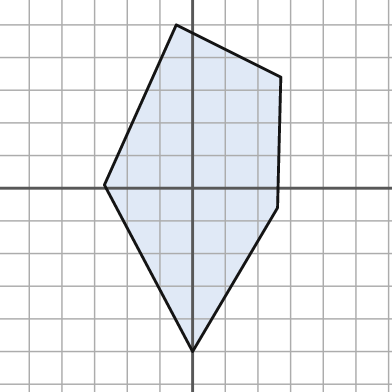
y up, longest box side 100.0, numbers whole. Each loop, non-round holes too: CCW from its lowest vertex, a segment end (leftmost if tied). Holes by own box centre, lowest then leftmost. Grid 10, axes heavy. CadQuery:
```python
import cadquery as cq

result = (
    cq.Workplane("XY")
    .moveTo(0.0, -50.0)
    .lineTo(26.0, -6.0)
    .lineTo(27.0, 34.0)
    .lineTo(-5.0, 50.0)
    .lineTo(-27.0, 1.0)
    .close()
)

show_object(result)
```